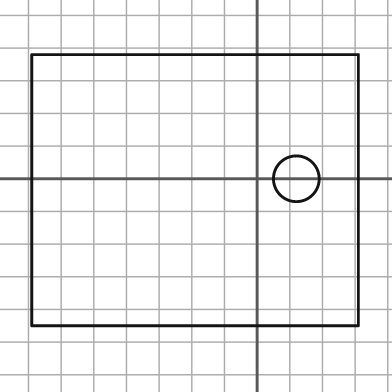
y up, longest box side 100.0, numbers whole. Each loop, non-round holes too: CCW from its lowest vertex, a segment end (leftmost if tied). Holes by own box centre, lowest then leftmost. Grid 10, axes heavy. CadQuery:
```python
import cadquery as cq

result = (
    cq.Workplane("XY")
    .moveTo(-69.0, -45.0)
    .lineTo(31.0, -45.0)
    .lineTo(31.0, 38.0)
    .lineTo(-69.0, 38.0)
    .close()
    .moveTo(12.0, 0.0)
    .circle(7.0)
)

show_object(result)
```